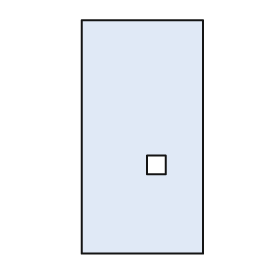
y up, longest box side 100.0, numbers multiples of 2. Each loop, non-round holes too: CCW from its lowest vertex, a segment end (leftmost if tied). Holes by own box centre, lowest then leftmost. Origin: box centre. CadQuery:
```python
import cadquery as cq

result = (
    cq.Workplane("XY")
    .moveTo(-26.0, -50.0)
    .lineTo(26.0, -50.0)
    .lineTo(26.0, 50.0)
    .lineTo(-26.0, 50.0)
    .close()
    .moveTo(2.0, -16.0)
    .lineTo(10.0, -16.0)
    .lineTo(10.0, -8.0)
    .lineTo(2.0, -8.0)
    .close()
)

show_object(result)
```